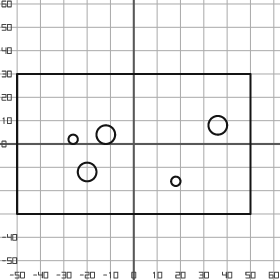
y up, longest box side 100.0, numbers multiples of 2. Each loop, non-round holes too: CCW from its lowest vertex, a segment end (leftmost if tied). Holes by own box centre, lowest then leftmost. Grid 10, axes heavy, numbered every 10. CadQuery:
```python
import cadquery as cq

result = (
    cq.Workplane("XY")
    .moveTo(-50.0, -30.0)
    .lineTo(50.0, -30.0)
    .lineTo(50.0, 30.0)
    .lineTo(-50.0, 30.0)
    .close()
    .moveTo(18.0, -16.0)
    .circle(2.0)
    .moveTo(-20.0, -12.0)
    .circle(4.0)
    .moveTo(-26.0, 2.0)
    .circle(2.0)
    .moveTo(-12.0, 4.0)
    .circle(4.0)
    .moveTo(36.0, 8.0)
    .circle(4.0)
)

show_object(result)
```